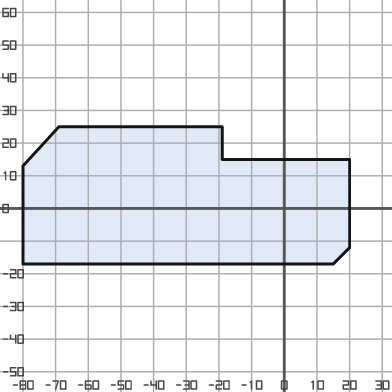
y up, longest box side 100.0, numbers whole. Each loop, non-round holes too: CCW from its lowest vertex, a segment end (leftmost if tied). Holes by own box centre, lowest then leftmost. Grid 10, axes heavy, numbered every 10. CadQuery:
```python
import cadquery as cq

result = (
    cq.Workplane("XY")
    .moveTo(-80.0, -17.0)
    .lineTo(15.0, -17.0)
    .lineTo(20.0, -12.0)
    .lineTo(20.0, 15.0)
    .lineTo(-19.0, 15.0)
    .lineTo(-19.0, 25.0)
    .lineTo(-69.0, 25.0)
    .lineTo(-80.0, 13.0)
    .close()
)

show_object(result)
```